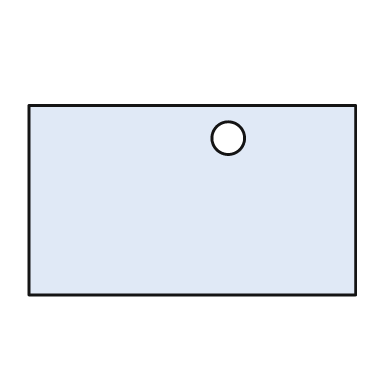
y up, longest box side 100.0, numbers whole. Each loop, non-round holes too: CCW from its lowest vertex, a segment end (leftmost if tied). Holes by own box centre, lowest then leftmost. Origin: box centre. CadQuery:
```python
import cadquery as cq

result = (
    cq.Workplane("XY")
    .moveTo(-50.0, -29.0)
    .lineTo(50.0, -29.0)
    .lineTo(50.0, 29.0)
    .lineTo(-50.0, 29.0)
    .close()
    .moveTo(11.0, 19.0)
    .circle(5.0)
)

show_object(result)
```